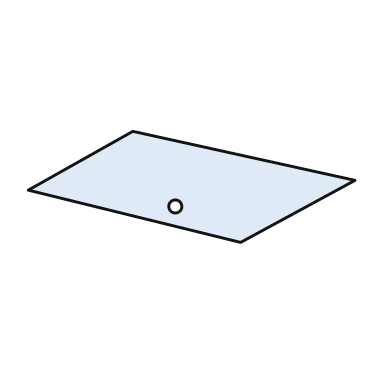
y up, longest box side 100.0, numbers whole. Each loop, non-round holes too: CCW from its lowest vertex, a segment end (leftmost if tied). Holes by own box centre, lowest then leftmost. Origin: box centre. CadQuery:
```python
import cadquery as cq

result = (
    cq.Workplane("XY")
    .moveTo(15.0, -17.0)
    .lineTo(50.0, 2.0)
    .lineTo(-18.0, 17.0)
    .lineTo(-50.0, -1.0)
    .close()
    .moveTo(-5.0, -6.0)
    .circle(2.0)
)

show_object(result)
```